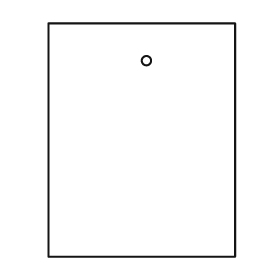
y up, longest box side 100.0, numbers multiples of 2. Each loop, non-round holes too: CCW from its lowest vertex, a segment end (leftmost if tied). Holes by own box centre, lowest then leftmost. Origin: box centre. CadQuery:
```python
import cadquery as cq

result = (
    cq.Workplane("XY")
    .moveTo(-40.0, -50.0)
    .lineTo(40.0, -50.0)
    .lineTo(40.0, 50.0)
    .lineTo(-40.0, 50.0)
    .close()
    .moveTo(2.0, 34.0)
    .circle(2.0)
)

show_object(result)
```